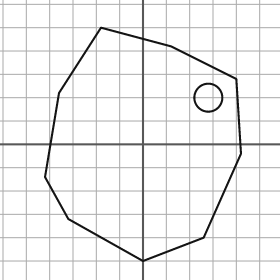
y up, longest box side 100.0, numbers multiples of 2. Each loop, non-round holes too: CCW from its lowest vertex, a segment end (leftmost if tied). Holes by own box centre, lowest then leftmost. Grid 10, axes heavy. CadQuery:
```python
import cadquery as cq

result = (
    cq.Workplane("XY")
    .moveTo(0.0, -50.0)
    .lineTo(26.0, -40.0)
    .lineTo(42.0, -4.0)
    .lineTo(40.0, 28.0)
    .lineTo(12.0, 42.0)
    .lineTo(-18.0, 50.0)
    .lineTo(-36.0, 22.0)
    .lineTo(-42.0, -14.0)
    .lineTo(-32.0, -32.0)
    .close()
    .moveTo(28.0, 20.0)
    .circle(6.0)
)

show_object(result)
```